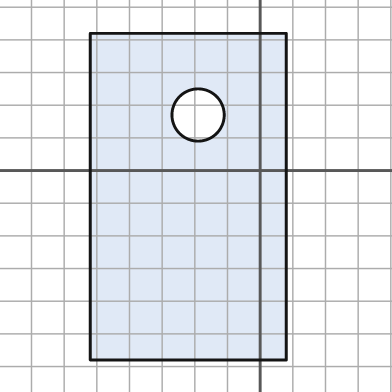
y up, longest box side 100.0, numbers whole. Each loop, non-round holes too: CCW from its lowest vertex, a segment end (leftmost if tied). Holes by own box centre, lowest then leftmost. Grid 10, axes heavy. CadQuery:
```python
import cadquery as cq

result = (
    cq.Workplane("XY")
    .moveTo(-52.0, -58.0)
    .lineTo(8.0, -58.0)
    .lineTo(8.0, 42.0)
    .lineTo(-52.0, 42.0)
    .close()
    .moveTo(-19.0, 17.0)
    .circle(8.0)
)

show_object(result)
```